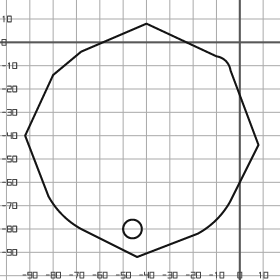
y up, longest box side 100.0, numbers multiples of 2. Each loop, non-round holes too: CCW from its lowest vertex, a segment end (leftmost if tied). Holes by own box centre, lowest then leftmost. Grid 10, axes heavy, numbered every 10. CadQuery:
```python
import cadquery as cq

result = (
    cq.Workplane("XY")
    .moveTo(-44.0, -92.0)
    .lineTo(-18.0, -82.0)
    .threePointArc((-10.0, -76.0), (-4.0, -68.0))
    .lineTo(8.0, -44.0)
    .lineTo(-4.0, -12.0)
    .threePointArc((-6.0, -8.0), (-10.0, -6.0))
    .lineTo(-40.0, 8.0)
    .lineTo(-68.0, -4.0)
    .lineTo(-80.0, -14.0)
    .lineTo(-92.0, -40.0)
    .lineTo(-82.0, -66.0)
    .threePointArc((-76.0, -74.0), (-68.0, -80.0))
    .close()
    .moveTo(-46.0, -80.0)
    .circle(4.0)
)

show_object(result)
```